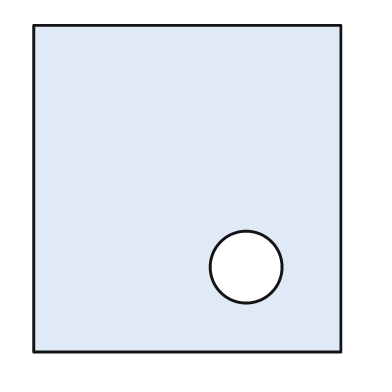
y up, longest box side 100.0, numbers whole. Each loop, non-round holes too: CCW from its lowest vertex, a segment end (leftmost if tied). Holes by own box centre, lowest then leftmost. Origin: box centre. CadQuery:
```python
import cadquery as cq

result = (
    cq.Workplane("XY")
    .moveTo(-47.0, -50.0)
    .lineTo(47.0, -50.0)
    .lineTo(47.0, 50.0)
    .lineTo(-47.0, 50.0)
    .close()
    .moveTo(18.0, -24.0)
    .circle(11.0)
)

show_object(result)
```